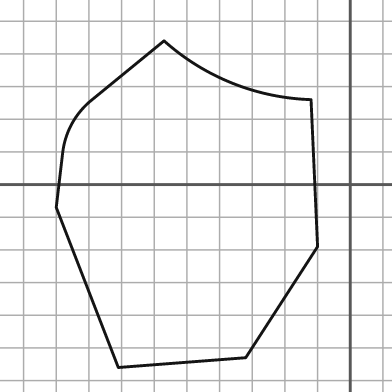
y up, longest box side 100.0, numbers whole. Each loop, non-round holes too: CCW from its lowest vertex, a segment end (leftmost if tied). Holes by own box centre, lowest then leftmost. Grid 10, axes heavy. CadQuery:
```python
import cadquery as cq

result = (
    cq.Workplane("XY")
    .moveTo(-71.0, -56.0)
    .lineTo(-32.0, -53.0)
    .lineTo(-10.0, -19.0)
    .lineTo(-12.0, 26.0)
    .threePointArc((-36.0, 31.0), (-57.0, 44.0))
    .lineTo(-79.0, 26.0)
    .threePointArc((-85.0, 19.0), (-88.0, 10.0))
    .lineTo(-90.0, -7.0)
    .close()
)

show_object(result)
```